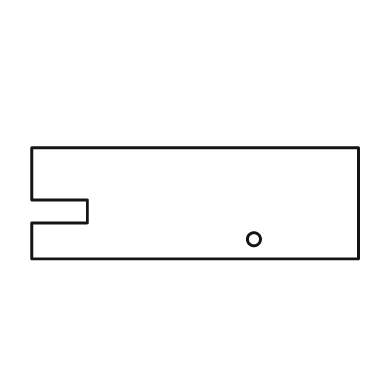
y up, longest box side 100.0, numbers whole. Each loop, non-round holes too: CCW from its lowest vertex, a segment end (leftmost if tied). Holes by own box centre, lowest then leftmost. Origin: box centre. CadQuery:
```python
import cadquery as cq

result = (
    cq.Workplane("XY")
    .moveTo(-50.0, -17.0)
    .lineTo(50.0, -17.0)
    .lineTo(50.0, 17.0)
    .lineTo(-50.0, 17.0)
    .lineTo(-50.0, 1.0)
    .lineTo(-33.0, 1.0)
    .lineTo(-33.0, -6.0)
    .lineTo(-50.0, -6.0)
    .close()
    .moveTo(18.0, -11.0)
    .circle(2.0)
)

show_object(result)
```